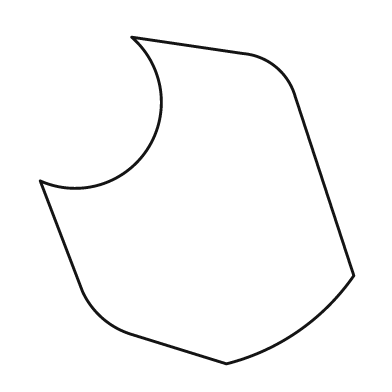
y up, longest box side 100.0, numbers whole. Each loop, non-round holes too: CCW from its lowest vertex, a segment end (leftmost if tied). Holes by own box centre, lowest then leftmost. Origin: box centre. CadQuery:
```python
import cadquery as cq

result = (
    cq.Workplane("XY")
    .moveTo(9.0, -50.0)
    .threePointArc((31.0, -40.0), (48.0, -23.0))
    .lineTo(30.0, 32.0)
    .threePointArc((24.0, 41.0), (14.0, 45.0))
    .lineTo(-20.0, 50.0)
    .threePointArc((-15.0, 16.0), (-48.0, 6.0))
    .lineTo(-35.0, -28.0)
    .threePointArc((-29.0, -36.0), (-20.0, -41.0))
    .close()
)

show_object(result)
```